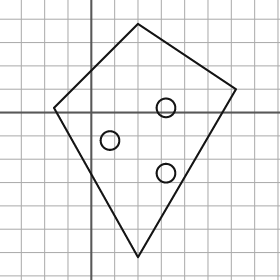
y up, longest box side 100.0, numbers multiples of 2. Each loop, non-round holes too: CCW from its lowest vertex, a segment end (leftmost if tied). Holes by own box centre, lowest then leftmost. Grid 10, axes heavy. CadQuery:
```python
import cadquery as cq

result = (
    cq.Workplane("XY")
    .moveTo(20.0, -62.0)
    .lineTo(62.0, 10.0)
    .lineTo(20.0, 38.0)
    .lineTo(-16.0, 2.0)
    .close()
    .moveTo(32.0, -26.0)
    .circle(4.0)
    .moveTo(8.0, -12.0)
    .circle(4.0)
    .moveTo(32.0, 2.0)
    .circle(4.0)
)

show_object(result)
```